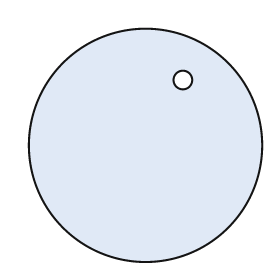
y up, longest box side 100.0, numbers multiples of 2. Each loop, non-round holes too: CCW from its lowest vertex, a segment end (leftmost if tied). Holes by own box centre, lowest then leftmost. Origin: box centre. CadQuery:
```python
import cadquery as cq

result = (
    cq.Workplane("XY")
    .moveTo(0.0, 0.0)
    .circle(50.0)
    .moveTo(16.0, 28.0)
    .circle(4.0)
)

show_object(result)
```